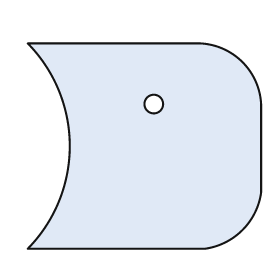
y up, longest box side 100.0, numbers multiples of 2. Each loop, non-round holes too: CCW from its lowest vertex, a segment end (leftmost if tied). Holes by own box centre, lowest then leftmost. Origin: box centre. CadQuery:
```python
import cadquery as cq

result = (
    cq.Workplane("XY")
    .moveTo(-50.0, -44.0)
    .lineTo(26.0, -44.0)
    .threePointArc((42.0, -36.0), (50.0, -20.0))
    .lineTo(50.0, 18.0)
    .threePointArc((42.0, 36.0), (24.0, 44.0))
    .lineTo(-50.0, 44.0)
    .threePointArc((-32.0, 0.0), (-50.0, -44.0))
    .close()
    .moveTo(4.0, 18.0)
    .circle(4.0)
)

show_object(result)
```